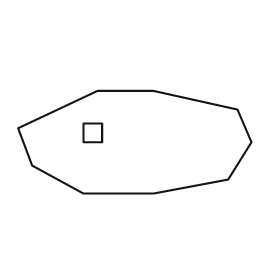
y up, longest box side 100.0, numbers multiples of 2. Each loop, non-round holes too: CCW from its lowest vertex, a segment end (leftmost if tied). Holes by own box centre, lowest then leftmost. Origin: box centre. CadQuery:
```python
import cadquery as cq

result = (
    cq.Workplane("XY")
    .moveTo(-22.0, -22.0)
    .lineTo(8.0, -22.0)
    .lineTo(40.0, -16.0)
    .lineTo(50.0, 0.0)
    .lineTo(44.0, 14.0)
    .lineTo(8.0, 22.0)
    .lineTo(-16.0, 22.0)
    .lineTo(-50.0, 6.0)
    .lineTo(-44.0, -10.0)
    .close()
    .moveTo(-22.0, 0.0)
    .lineTo(-14.0, 0.0)
    .lineTo(-14.0, 8.0)
    .lineTo(-22.0, 8.0)
    .close()
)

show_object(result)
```